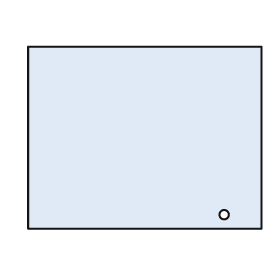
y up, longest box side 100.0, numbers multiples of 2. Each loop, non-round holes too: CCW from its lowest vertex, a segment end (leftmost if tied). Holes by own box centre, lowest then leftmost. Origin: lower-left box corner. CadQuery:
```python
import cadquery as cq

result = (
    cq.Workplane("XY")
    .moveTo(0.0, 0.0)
    .lineTo(100.0, 0.0)
    .lineTo(100.0, 78.0)
    .lineTo(0.0, 78.0)
    .close()
    .moveTo(84.0, 6.0)
    .circle(2.0)
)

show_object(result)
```